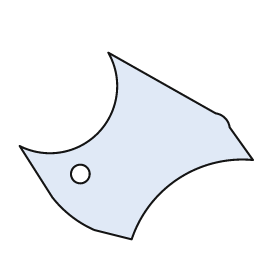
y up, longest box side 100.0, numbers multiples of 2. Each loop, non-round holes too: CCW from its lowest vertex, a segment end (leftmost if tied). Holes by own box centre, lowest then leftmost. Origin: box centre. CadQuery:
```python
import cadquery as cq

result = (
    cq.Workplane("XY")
    .moveTo(-2.0, -40.0)
    .threePointArc((18.0, -14.0), (50.0, -6.0))
    .lineTo(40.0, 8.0)
    .threePointArc((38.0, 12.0), (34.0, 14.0))
    .lineTo(-12.0, 40.0)
    .threePointArc((-16.0, 6.0), (-50.0, 0.0))
    .lineTo(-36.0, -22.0)
    .threePointArc((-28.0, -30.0), (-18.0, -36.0))
    .close()
    .moveTo(-24.0, -12.0)
    .circle(4.0)
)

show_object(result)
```